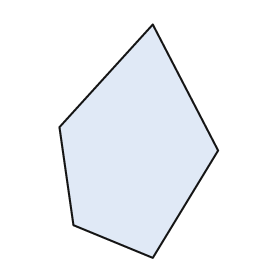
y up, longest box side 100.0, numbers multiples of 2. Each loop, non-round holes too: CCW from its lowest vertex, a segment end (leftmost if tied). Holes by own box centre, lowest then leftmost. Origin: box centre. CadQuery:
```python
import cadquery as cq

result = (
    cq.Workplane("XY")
    .moveTo(6.0, -50.0)
    .lineTo(34.0, -4.0)
    .lineTo(6.0, 50.0)
    .lineTo(-34.0, 6.0)
    .lineTo(-28.0, -36.0)
    .close()
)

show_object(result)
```